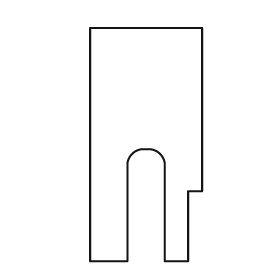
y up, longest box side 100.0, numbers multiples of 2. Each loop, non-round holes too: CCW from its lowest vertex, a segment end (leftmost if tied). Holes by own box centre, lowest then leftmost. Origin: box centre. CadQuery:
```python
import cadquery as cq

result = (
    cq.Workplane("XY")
    .moveTo(-24.0, -50.0)
    .lineTo(-8.0, -50.0)
    .lineTo(-8.0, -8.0)
    .threePointArc((-6.0, -4.0), (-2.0, -2.0))
    .lineTo(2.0, -2.0)
    .threePointArc((6.0, -4.0), (8.0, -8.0))
    .lineTo(8.0, -50.0)
    .lineTo(18.0, -50.0)
    .lineTo(18.0, -20.0)
    .lineTo(24.0, -20.0)
    .lineTo(24.0, 50.0)
    .lineTo(-24.0, 50.0)
    .close()
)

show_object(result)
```